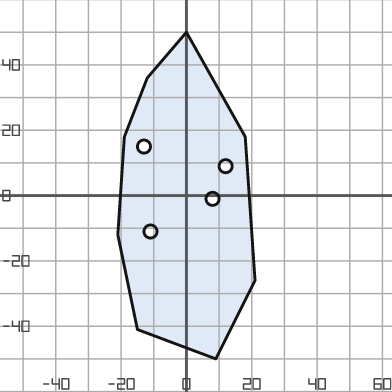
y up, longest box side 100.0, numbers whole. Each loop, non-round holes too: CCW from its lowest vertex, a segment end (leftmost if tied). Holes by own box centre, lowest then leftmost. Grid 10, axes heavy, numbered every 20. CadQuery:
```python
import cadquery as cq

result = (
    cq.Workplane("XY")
    .moveTo(9.0, -50.0)
    .lineTo(21.0, -26.0)
    .lineTo(18.0, 18.0)
    .lineTo(0.0, 50.0)
    .lineTo(-12.0, 36.0)
    .lineTo(-19.0, 18.0)
    .lineTo(-21.0, -12.0)
    .lineTo(-15.0, -41.0)
    .close()
    .moveTo(-11.0, -11.0)
    .circle(2.0)
    .moveTo(8.0, -1.0)
    .circle(2.0)
    .moveTo(12.0, 9.0)
    .circle(2.0)
    .moveTo(-13.0, 15.0)
    .circle(2.0)
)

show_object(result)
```